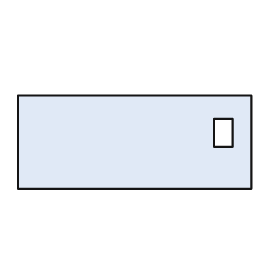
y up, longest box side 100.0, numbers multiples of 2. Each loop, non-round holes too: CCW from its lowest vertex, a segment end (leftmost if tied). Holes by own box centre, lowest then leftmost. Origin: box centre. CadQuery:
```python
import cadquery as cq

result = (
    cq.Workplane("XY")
    .moveTo(-50.0, -20.0)
    .lineTo(50.0, -20.0)
    .lineTo(50.0, 20.0)
    .lineTo(-50.0, 20.0)
    .close()
    .moveTo(34.0, -2.0)
    .lineTo(42.0, -2.0)
    .lineTo(42.0, 10.0)
    .lineTo(34.0, 10.0)
    .close()
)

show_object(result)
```